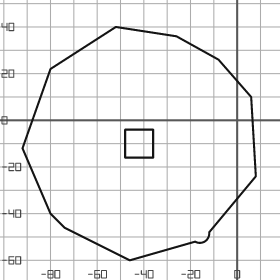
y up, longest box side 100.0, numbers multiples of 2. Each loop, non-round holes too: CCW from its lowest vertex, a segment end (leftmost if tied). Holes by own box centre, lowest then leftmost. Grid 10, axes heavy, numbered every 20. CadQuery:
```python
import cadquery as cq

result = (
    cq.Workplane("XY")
    .moveTo(-46.0, -60.0)
    .lineTo(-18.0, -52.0)
    .threePointArc((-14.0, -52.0), (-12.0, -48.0))
    .lineTo(8.0, -24.0)
    .lineTo(6.0, 10.0)
    .lineTo(-8.0, 26.0)
    .lineTo(-26.0, 36.0)
    .lineTo(-52.0, 40.0)
    .lineTo(-80.0, 22.0)
    .lineTo(-92.0, -12.0)
    .lineTo(-80.0, -40.0)
    .lineTo(-74.0, -46.0)
    .close()
    .moveTo(-48.0, -16.0)
    .lineTo(-36.0, -16.0)
    .lineTo(-36.0, -4.0)
    .lineTo(-48.0, -4.0)
    .close()
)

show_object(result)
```